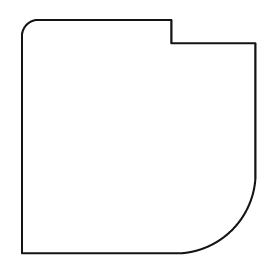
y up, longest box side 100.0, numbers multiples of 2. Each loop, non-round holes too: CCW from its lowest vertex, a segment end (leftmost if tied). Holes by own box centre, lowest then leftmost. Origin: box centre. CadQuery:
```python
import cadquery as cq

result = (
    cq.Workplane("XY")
    .moveTo(-50.0, -50.0)
    .lineTo(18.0, -50.0)
    .threePointArc((40.0, -40.0), (50.0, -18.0))
    .lineTo(50.0, 40.0)
    .lineTo(14.0, 40.0)
    .lineTo(14.0, 50.0)
    .lineTo(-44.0, 50.0)
    .threePointArc((-48.0, 48.0), (-50.0, 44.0))
    .close()
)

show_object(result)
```